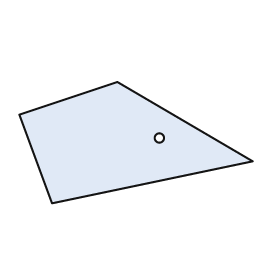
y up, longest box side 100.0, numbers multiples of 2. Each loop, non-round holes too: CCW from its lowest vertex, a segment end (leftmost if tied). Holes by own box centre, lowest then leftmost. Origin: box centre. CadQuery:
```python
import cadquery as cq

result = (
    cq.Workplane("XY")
    .moveTo(-36.0, -26.0)
    .lineTo(50.0, -8.0)
    .lineTo(-8.0, 26.0)
    .lineTo(-50.0, 12.0)
    .close()
    .moveTo(10.0, 2.0)
    .circle(2.0)
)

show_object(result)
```